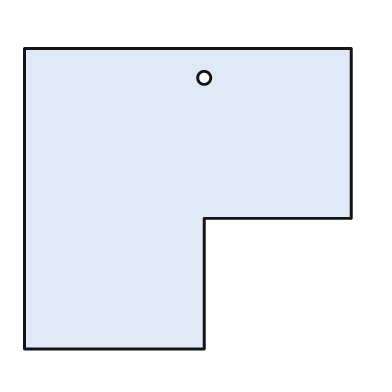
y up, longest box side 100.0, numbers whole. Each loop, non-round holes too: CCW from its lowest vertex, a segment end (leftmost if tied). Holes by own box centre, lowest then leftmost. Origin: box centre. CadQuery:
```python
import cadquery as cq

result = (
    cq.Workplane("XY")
    .moveTo(-50.0, -46.0)
    .lineTo(5.0, -46.0)
    .lineTo(5.0, -6.0)
    .lineTo(50.0, -6.0)
    .lineTo(50.0, 46.0)
    .lineTo(-50.0, 46.0)
    .close()
    .moveTo(5.0, 37.0)
    .circle(2.0)
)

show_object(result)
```